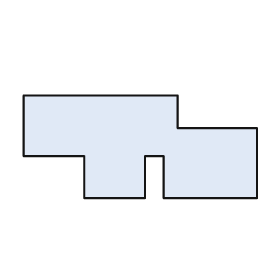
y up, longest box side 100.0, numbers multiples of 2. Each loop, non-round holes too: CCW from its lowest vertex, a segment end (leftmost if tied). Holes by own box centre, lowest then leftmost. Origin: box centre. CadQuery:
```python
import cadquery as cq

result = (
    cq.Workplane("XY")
    .moveTo(-24.0, -22.0)
    .lineTo(2.0, -22.0)
    .lineTo(2.0, -4.0)
    .lineTo(10.0, -4.0)
    .lineTo(10.0, -22.0)
    .lineTo(50.0, -22.0)
    .lineTo(50.0, 8.0)
    .lineTo(16.0, 8.0)
    .lineTo(16.0, 22.0)
    .lineTo(-50.0, 22.0)
    .lineTo(-50.0, -4.0)
    .lineTo(-24.0, -4.0)
    .close()
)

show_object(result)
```